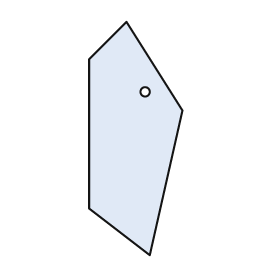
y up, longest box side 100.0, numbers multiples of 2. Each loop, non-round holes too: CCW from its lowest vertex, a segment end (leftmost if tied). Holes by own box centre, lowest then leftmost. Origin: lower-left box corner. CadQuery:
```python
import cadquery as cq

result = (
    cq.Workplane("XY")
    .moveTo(26.0, 0.0)
    .lineTo(40.0, 62.0)
    .lineTo(16.0, 100.0)
    .lineTo(0.0, 84.0)
    .lineTo(0.0, 20.0)
    .close()
    .moveTo(24.0, 70.0)
    .circle(2.0)
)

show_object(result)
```